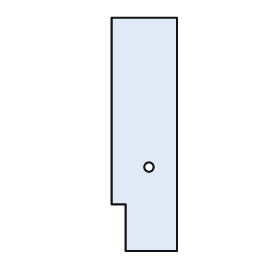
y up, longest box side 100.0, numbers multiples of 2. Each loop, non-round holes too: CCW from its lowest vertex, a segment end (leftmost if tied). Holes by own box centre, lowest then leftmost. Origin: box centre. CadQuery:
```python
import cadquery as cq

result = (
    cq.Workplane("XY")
    .moveTo(-8.0, -50.0)
    .lineTo(14.0, -50.0)
    .lineTo(14.0, 50.0)
    .lineTo(-14.0, 50.0)
    .lineTo(-14.0, -30.0)
    .lineTo(-8.0, -30.0)
    .close()
    .moveTo(2.0, -14.0)
    .circle(2.0)
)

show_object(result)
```